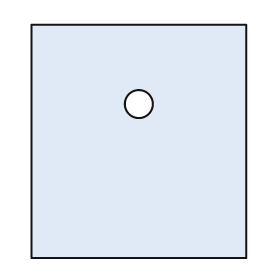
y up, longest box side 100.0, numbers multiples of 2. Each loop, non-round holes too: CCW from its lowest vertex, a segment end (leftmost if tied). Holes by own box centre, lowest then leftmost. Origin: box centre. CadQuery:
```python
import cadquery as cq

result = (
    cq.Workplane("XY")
    .moveTo(-46.0, -50.0)
    .lineTo(46.0, -50.0)
    .lineTo(46.0, 50.0)
    .lineTo(-46.0, 50.0)
    .close()
    .moveTo(0.0, 16.0)
    .circle(6.0)
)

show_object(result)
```